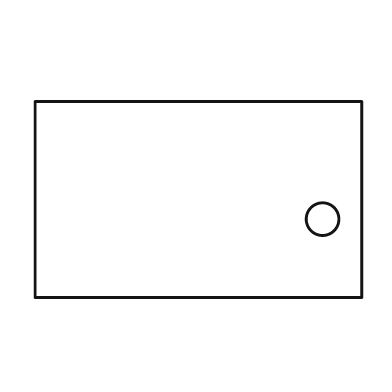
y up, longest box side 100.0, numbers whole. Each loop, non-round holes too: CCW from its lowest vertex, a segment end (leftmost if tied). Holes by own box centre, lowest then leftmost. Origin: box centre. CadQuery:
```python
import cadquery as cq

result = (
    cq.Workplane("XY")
    .moveTo(-50.0, -30.0)
    .lineTo(50.0, -30.0)
    .lineTo(50.0, 30.0)
    .lineTo(-50.0, 30.0)
    .close()
    .moveTo(38.0, -6.0)
    .circle(5.0)
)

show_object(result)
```